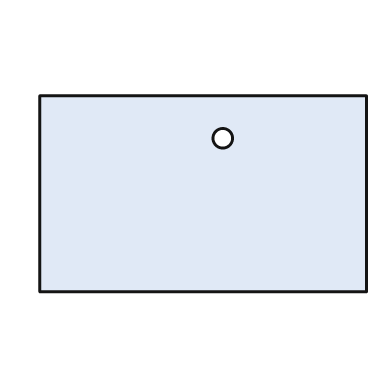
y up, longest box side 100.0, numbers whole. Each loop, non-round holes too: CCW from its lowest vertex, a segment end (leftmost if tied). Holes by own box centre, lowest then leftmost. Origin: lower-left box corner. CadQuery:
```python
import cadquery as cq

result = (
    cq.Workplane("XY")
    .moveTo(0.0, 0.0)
    .lineTo(100.0, 0.0)
    .lineTo(100.0, 60.0)
    .lineTo(0.0, 60.0)
    .close()
    .moveTo(56.0, 47.0)
    .circle(3.0)
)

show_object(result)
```